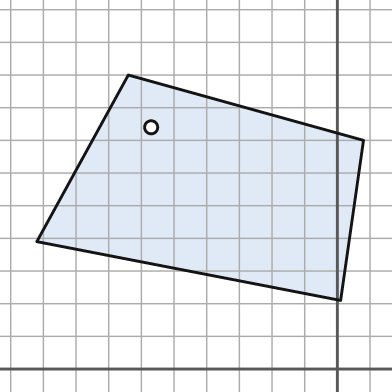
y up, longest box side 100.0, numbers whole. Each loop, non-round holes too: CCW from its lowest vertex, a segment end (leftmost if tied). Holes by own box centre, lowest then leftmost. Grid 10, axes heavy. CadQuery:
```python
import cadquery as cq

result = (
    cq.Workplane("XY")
    .moveTo(1.0, 21.0)
    .lineTo(8.0, 70.0)
    .lineTo(-64.0, 90.0)
    .lineTo(-92.0, 39.0)
    .close()
    .moveTo(-57.0, 74.0)
    .circle(2.0)
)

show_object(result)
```